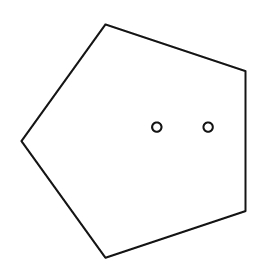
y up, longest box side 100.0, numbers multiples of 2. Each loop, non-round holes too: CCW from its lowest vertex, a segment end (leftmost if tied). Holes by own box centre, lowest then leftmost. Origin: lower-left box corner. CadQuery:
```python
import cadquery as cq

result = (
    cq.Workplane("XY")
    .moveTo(36.0, 0.0)
    .lineTo(96.0, 20.0)
    .lineTo(96.0, 80.0)
    .lineTo(36.0, 100.0)
    .lineTo(0.0, 50.0)
    .close()
    .moveTo(58.0, 56.0)
    .circle(2.0)
    .moveTo(80.0, 56.0)
    .circle(2.0)
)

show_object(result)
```